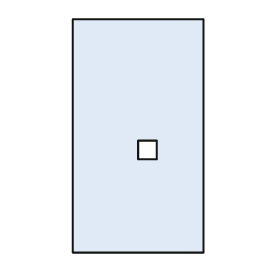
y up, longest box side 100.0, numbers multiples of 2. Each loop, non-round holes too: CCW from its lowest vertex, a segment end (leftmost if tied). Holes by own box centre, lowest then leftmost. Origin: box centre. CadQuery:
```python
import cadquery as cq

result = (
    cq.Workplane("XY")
    .moveTo(-28.0, -50.0)
    .lineTo(28.0, -50.0)
    .lineTo(28.0, 50.0)
    .lineTo(-28.0, 50.0)
    .close()
    .moveTo(0.0, -10.0)
    .lineTo(8.0, -10.0)
    .lineTo(8.0, -2.0)
    .lineTo(0.0, -2.0)
    .close()
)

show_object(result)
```